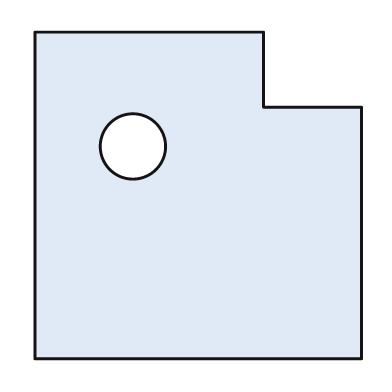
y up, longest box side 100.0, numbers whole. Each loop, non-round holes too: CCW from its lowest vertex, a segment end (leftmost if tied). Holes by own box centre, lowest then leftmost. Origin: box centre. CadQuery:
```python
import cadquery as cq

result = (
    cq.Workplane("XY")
    .moveTo(-50.0, -50.0)
    .lineTo(50.0, -50.0)
    .lineTo(50.0, 27.0)
    .lineTo(20.0, 27.0)
    .lineTo(20.0, 50.0)
    .lineTo(-50.0, 50.0)
    .close()
    .moveTo(-20.0, 15.0)
    .circle(10.0)
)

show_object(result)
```